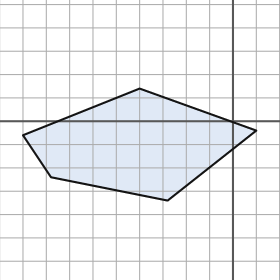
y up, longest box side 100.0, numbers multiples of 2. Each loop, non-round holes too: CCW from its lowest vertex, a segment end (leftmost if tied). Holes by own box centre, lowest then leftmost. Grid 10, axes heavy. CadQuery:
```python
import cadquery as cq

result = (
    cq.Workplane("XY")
    .moveTo(-28.0, -34.0)
    .lineTo(10.0, -4.0)
    .lineTo(-40.0, 14.0)
    .lineTo(-90.0, -6.0)
    .lineTo(-78.0, -24.0)
    .close()
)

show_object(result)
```